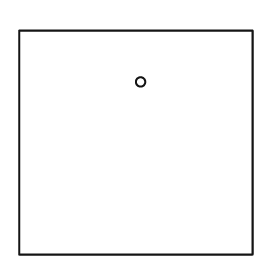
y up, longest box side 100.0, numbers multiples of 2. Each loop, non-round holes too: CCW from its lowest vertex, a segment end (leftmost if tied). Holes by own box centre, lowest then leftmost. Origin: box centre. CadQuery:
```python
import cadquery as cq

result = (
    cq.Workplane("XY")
    .moveTo(-50.0, -48.0)
    .lineTo(50.0, -48.0)
    .lineTo(50.0, 48.0)
    .lineTo(-50.0, 48.0)
    .close()
    .moveTo(2.0, 26.0)
    .circle(2.0)
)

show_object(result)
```